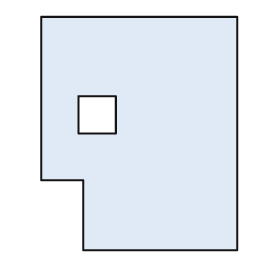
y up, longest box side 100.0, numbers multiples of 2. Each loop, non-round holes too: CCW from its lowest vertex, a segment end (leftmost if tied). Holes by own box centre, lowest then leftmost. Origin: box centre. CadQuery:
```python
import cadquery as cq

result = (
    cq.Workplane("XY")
    .moveTo(-24.0, -50.0)
    .lineTo(42.0, -50.0)
    .lineTo(42.0, 50.0)
    .lineTo(-42.0, 50.0)
    .lineTo(-42.0, -20.0)
    .lineTo(-24.0, -20.0)
    .close()
    .moveTo(-26.0, 0.0)
    .lineTo(-10.0, 0.0)
    .lineTo(-10.0, 16.0)
    .lineTo(-26.0, 16.0)
    .close()
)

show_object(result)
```